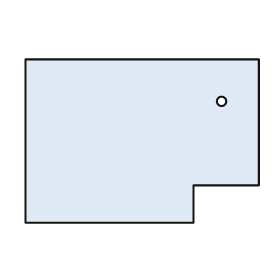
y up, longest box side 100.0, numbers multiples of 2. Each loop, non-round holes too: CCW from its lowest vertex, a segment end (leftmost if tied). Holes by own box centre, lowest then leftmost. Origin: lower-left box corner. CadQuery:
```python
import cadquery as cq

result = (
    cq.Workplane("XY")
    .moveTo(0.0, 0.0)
    .lineTo(72.0, 0.0)
    .lineTo(72.0, 16.0)
    .lineTo(100.0, 16.0)
    .lineTo(100.0, 70.0)
    .lineTo(0.0, 70.0)
    .close()
    .moveTo(84.0, 52.0)
    .circle(2.0)
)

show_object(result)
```